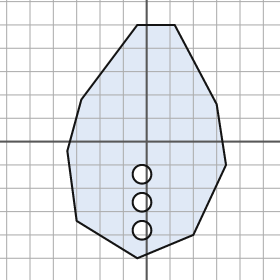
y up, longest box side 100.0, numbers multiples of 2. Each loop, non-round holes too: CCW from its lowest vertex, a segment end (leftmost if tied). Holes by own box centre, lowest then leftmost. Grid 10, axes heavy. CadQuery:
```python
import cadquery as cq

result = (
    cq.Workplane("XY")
    .moveTo(-4.0, -50.0)
    .lineTo(20.0, -40.0)
    .lineTo(34.0, -10.0)
    .lineTo(30.0, 16.0)
    .lineTo(12.0, 50.0)
    .lineTo(-4.0, 50.0)
    .lineTo(-28.0, 18.0)
    .lineTo(-34.0, -4.0)
    .lineTo(-30.0, -34.0)
    .close()
    .moveTo(-2.0, -38.0)
    .circle(4.0)
    .moveTo(-2.0, -26.0)
    .circle(4.0)
    .moveTo(-2.0, -14.0)
    .circle(4.0)
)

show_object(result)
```